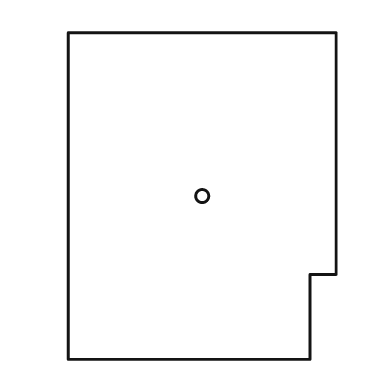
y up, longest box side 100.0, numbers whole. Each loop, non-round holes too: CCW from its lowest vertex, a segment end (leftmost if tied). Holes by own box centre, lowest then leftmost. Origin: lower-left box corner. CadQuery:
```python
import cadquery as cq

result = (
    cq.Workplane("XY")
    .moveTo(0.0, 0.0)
    .lineTo(74.0, 0.0)
    .lineTo(74.0, 26.0)
    .lineTo(82.0, 26.0)
    .lineTo(82.0, 100.0)
    .lineTo(0.0, 100.0)
    .close()
    .moveTo(41.0, 50.0)
    .circle(2.0)
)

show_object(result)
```